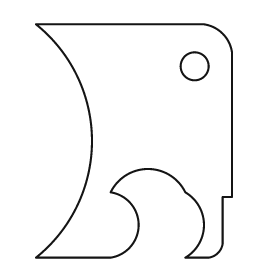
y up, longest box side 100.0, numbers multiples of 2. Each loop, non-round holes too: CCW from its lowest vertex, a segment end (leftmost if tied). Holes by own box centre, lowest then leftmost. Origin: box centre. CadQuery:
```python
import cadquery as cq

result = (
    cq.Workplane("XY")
    .moveTo(-42.0, -50.0)
    .lineTo(-10.0, -50.0)
    .threePointArc((2.0, -36.0), (-10.0, -22.0))
    .threePointArc((6.0, -12.0), (22.0, -22.0))
    .threePointArc((30.0, -36.0), (22.0, -50.0))
    .lineTo(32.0, -50.0)
    .threePointArc((36.0, -48.0), (38.0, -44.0))
    .lineTo(38.0, -24.0)
    .lineTo(42.0, -24.0)
    .lineTo(42.0, 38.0)
    .threePointArc((38.0, 46.0), (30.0, 50.0))
    .lineTo(-42.0, 50.0)
    .threePointArc((-18.0, 0.0), (-42.0, -50.0))
    .close()
    .moveTo(26.0, 32.0)
    .circle(6.0)
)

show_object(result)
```